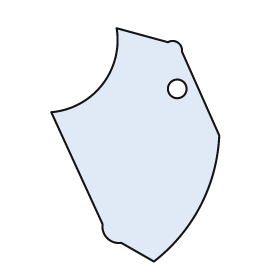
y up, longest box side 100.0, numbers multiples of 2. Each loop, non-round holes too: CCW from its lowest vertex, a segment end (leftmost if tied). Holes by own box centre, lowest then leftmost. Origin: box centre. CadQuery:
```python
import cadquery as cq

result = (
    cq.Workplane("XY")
    .moveTo(8.0, -50.0)
    .threePointArc((28.0, -26.0), (36.0, 4.0))
    .lineTo(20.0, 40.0)
    .threePointArc((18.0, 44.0), (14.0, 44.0))
    .lineTo(-8.0, 50.0)
    .threePointArc((-14.0, 26.0), (-36.0, 14.0))
    .lineTo(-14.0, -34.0)
    .threePointArc((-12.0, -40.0), (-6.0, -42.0))
    .close()
    .moveTo(18.0, 24.0)
    .circle(4.0)
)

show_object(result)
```